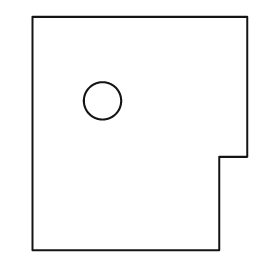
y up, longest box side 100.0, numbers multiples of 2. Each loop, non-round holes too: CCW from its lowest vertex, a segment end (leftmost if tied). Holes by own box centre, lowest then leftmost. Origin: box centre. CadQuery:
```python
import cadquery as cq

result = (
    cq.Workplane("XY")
    .moveTo(-46.0, -50.0)
    .lineTo(34.0, -50.0)
    .lineTo(34.0, -10.0)
    .lineTo(46.0, -10.0)
    .lineTo(46.0, 50.0)
    .lineTo(-46.0, 50.0)
    .close()
    .moveTo(-16.0, 14.0)
    .circle(8.0)
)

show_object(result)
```